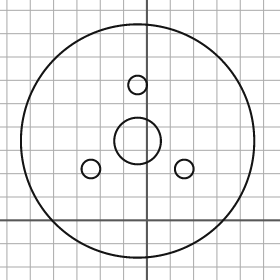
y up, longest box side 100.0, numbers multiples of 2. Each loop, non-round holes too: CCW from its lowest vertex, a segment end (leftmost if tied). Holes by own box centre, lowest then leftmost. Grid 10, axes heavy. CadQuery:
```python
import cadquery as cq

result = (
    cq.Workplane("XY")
    .moveTo(-4.0, 34.0)
    .circle(50.0)
    .moveTo(-24.0, 22.0)
    .circle(4.0)
    .moveTo(16.0, 22.0)
    .circle(4.0)
    .moveTo(-4.0, 34.0)
    .circle(10.0)
    .moveTo(-4.0, 58.0)
    .circle(4.0)
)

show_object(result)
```